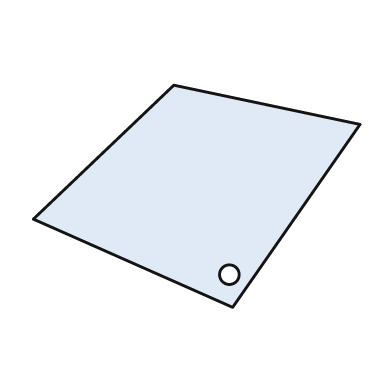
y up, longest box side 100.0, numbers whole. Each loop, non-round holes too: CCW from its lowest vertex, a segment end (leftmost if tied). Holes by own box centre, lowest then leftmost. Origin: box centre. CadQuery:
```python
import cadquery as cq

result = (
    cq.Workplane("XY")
    .moveTo(11.0, -34.0)
    .lineTo(50.0, 22.0)
    .lineTo(-7.0, 34.0)
    .lineTo(-50.0, -7.0)
    .close()
    .moveTo(10.0, -24.0)
    .circle(3.0)
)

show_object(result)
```